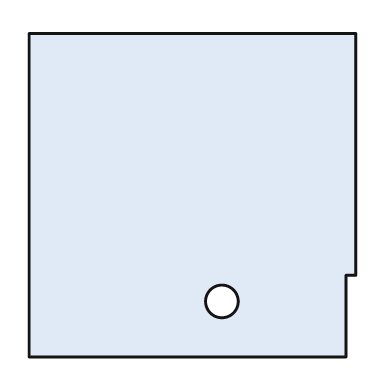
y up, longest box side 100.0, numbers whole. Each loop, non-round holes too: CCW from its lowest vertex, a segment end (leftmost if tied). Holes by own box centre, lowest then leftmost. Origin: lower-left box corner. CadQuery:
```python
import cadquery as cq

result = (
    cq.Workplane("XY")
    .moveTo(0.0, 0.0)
    .lineTo(97.0, 0.0)
    .lineTo(97.0, 25.0)
    .lineTo(100.0, 25.0)
    .lineTo(100.0, 99.0)
    .lineTo(0.0, 99.0)
    .close()
    .moveTo(59.0, 17.0)
    .circle(5.0)
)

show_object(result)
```